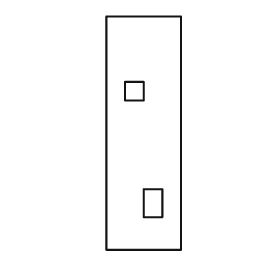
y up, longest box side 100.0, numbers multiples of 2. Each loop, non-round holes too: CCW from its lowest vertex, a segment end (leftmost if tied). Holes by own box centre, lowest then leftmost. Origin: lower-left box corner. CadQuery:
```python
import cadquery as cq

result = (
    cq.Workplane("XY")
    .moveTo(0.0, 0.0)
    .lineTo(32.0, 0.0)
    .lineTo(32.0, 100.0)
    .lineTo(0.0, 100.0)
    .close()
    .moveTo(16.0, 14.0)
    .lineTo(24.0, 14.0)
    .lineTo(24.0, 26.0)
    .lineTo(16.0, 26.0)
    .close()
    .moveTo(8.0, 64.0)
    .lineTo(16.0, 64.0)
    .lineTo(16.0, 72.0)
    .lineTo(8.0, 72.0)
    .close()
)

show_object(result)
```